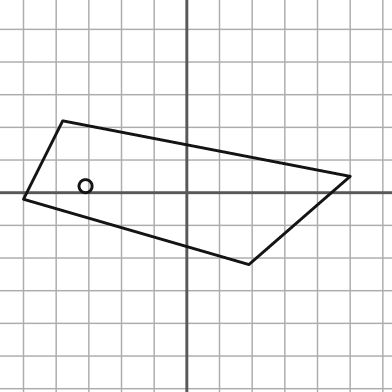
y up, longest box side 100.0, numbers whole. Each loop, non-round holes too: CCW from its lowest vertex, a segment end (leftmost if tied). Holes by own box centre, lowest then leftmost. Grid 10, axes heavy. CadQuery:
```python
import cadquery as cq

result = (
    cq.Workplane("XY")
    .moveTo(19.0, -22.0)
    .lineTo(50.0, 5.0)
    .lineTo(-38.0, 22.0)
    .lineTo(-50.0, -2.0)
    .close()
    .moveTo(-31.0, 2.0)
    .circle(2.0)
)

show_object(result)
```